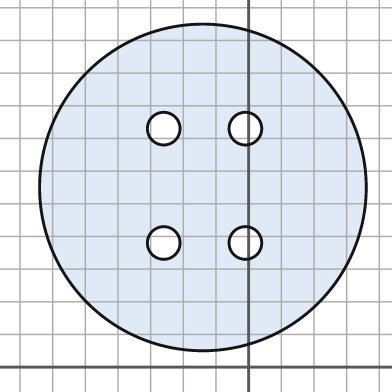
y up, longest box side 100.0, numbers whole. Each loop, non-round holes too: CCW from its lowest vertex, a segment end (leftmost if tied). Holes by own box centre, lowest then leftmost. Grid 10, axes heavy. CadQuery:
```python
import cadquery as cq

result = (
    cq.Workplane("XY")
    .moveTo(-14.0, 55.0)
    .circle(50.0)
    .moveTo(-26.0, 38.0)
    .circle(5.0)
    .moveTo(-1.0, 38.0)
    .circle(5.0)
    .moveTo(-26.0, 73.0)
    .circle(5.0)
    .moveTo(-1.0, 73.0)
    .circle(5.0)
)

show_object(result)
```